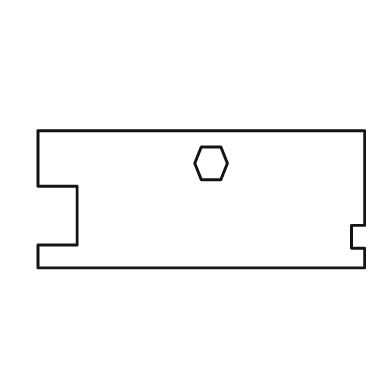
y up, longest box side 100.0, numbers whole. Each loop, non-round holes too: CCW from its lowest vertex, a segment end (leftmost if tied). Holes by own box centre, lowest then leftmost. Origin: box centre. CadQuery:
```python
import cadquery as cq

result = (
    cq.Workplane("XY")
    .moveTo(-50.0, -21.0)
    .lineTo(50.0, -21.0)
    .lineTo(50.0, -15.0)
    .lineTo(46.0, -15.0)
    .lineTo(46.0, -8.0)
    .lineTo(50.0, -8.0)
    .lineTo(50.0, 21.0)
    .lineTo(-50.0, 21.0)
    .lineTo(-50.0, 4.0)
    .lineTo(-38.0, 4.0)
    .lineTo(-38.0, -14.0)
    .lineTo(-50.0, -14.0)
    .close()
    .moveTo(0.0, 6.0)
    .lineTo(6.0, 6.0)
    .lineTo(8.0, 11.0)
    .lineTo(6.0, 16.0)
    .lineTo(0.0, 16.0)
    .lineTo(-2.0, 11.0)
    .close()
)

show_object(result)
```